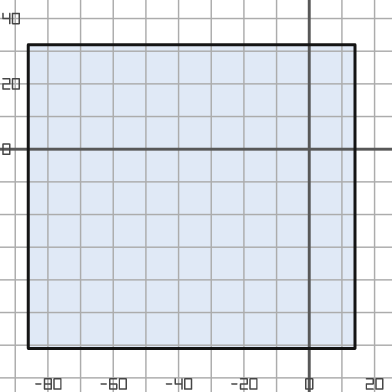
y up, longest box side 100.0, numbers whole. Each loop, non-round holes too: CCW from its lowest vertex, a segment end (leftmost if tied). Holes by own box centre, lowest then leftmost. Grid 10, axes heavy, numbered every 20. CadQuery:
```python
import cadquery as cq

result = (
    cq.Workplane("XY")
    .moveTo(-86.0, -61.0)
    .lineTo(14.0, -61.0)
    .lineTo(14.0, 32.0)
    .lineTo(-86.0, 32.0)
    .close()
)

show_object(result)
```